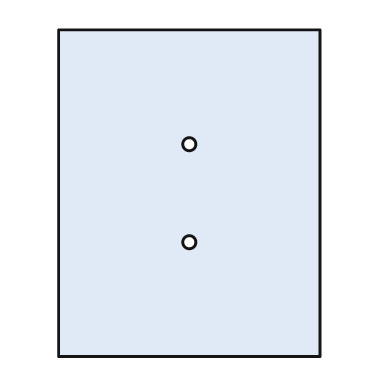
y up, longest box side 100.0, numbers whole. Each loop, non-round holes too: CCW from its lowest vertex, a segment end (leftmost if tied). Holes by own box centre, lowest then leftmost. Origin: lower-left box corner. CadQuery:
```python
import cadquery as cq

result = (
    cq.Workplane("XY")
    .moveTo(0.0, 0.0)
    .lineTo(80.0, 0.0)
    .lineTo(80.0, 100.0)
    .lineTo(0.0, 100.0)
    .close()
    .moveTo(40.0, 35.0)
    .circle(2.0)
    .moveTo(40.0, 65.0)
    .circle(2.0)
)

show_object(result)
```